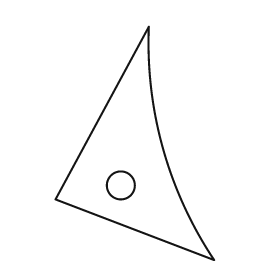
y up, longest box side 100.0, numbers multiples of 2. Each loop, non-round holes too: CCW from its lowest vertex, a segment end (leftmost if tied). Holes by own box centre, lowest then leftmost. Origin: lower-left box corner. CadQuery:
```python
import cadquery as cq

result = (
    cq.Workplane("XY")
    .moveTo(68.0, 0.0)
    .threePointArc((46.0, 48.0), (40.0, 100.0))
    .lineTo(0.0, 26.0)
    .close()
    .moveTo(28.0, 32.0)
    .circle(6.0)
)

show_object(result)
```